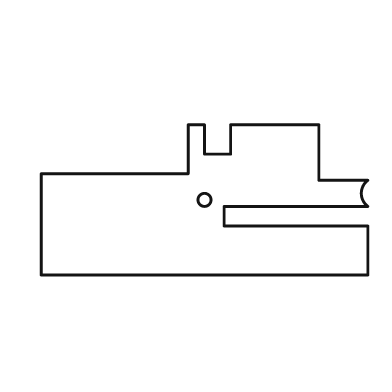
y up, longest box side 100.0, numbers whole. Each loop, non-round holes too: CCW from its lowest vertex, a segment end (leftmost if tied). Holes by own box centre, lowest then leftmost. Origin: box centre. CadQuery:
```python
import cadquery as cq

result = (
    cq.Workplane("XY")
    .moveTo(-50.0, -23.0)
    .lineTo(50.0, -23.0)
    .lineTo(50.0, -8.0)
    .lineTo(6.0, -8.0)
    .lineTo(6.0, -2.0)
    .lineTo(50.0, -2.0)
    .threePointArc((48.0, 2.0), (50.0, 6.0))
    .lineTo(35.0, 6.0)
    .lineTo(35.0, 23.0)
    .lineTo(8.0, 23.0)
    .lineTo(8.0, 14.0)
    .lineTo(0.0, 14.0)
    .lineTo(0.0, 23.0)
    .lineTo(-5.0, 23.0)
    .lineTo(-5.0, 8.0)
    .lineTo(-50.0, 8.0)
    .close()
    .moveTo(0.0, 0.0)
    .circle(2.0)
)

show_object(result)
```